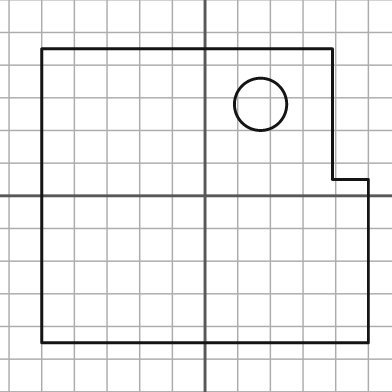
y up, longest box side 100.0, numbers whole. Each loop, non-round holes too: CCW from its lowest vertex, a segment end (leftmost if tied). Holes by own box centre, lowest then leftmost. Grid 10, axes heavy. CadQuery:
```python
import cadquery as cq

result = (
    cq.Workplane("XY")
    .moveTo(-50.0, -45.0)
    .lineTo(50.0, -45.0)
    .lineTo(50.0, 5.0)
    .lineTo(39.0, 5.0)
    .lineTo(39.0, 45.0)
    .lineTo(-50.0, 45.0)
    .close()
    .moveTo(17.0, 28.0)
    .circle(8.0)
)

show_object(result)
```